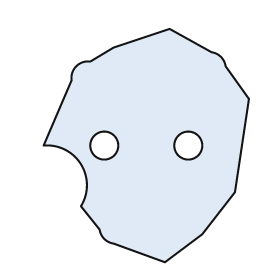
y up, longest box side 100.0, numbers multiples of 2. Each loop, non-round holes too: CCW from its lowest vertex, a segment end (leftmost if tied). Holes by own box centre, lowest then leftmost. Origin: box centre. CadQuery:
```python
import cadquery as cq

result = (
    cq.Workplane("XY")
    .moveTo(8.0, -50.0)
    .lineTo(24.0, -38.0)
    .lineTo(38.0, -20.0)
    .lineTo(44.0, 20.0)
    .lineTo(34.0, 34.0)
    .threePointArc((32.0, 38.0), (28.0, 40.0))
    .lineTo(10.0, 50.0)
    .lineTo(-14.0, 42.0)
    .lineTo(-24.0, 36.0)
    .threePointArc((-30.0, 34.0), (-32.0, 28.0))
    .lineTo(-44.0, 0.0)
    .threePointArc((-28.0, -8.0), (-28.0, -26.0))
    .lineTo(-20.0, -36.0)
    .threePointArc((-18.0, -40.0), (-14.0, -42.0))
    .close()
    .moveTo(-18.0, 0.0)
    .circle(6.0)
    .moveTo(18.0, 0.0)
    .circle(6.0)
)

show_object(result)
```